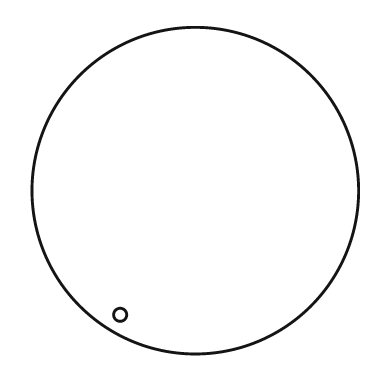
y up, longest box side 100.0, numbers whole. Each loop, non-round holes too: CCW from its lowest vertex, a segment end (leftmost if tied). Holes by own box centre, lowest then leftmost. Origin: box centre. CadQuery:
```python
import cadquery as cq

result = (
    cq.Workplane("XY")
    .moveTo(0.0, 0.0)
    .circle(50.0)
    .moveTo(-23.0, -38.0)
    .circle(2.0)
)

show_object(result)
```